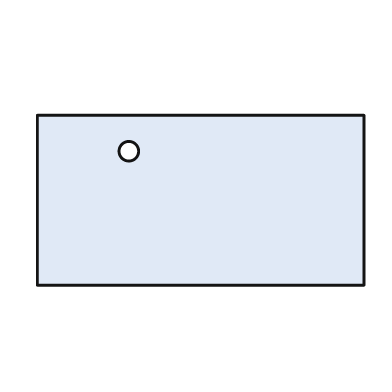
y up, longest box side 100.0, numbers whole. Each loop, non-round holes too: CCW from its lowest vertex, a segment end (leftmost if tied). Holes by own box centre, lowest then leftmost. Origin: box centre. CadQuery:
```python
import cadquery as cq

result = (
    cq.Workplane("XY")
    .moveTo(-50.0, -26.0)
    .lineTo(50.0, -26.0)
    .lineTo(50.0, 26.0)
    .lineTo(-50.0, 26.0)
    .close()
    .moveTo(-22.0, 15.0)
    .circle(3.0)
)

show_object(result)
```